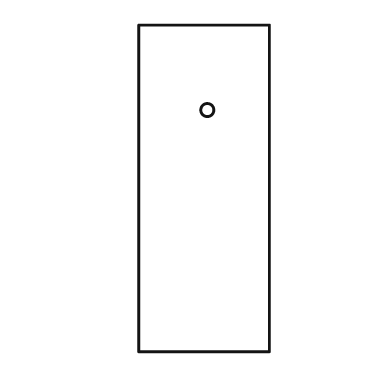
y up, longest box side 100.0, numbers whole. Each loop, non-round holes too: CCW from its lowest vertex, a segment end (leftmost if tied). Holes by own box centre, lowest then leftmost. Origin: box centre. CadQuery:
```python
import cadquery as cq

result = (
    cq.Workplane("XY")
    .moveTo(-20.0, -50.0)
    .lineTo(20.0, -50.0)
    .lineTo(20.0, 50.0)
    .lineTo(-20.0, 50.0)
    .close()
    .moveTo(1.0, 24.0)
    .circle(2.0)
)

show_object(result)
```